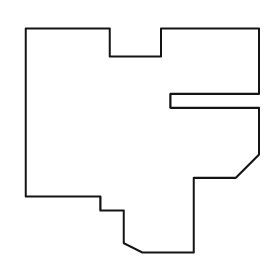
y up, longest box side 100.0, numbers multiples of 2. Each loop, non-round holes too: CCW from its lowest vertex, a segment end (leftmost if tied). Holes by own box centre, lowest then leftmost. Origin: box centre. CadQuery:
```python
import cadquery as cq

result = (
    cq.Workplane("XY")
    .moveTo(0.0, -48.0)
    .lineTo(22.0, -48.0)
    .lineTo(22.0, -16.0)
    .lineTo(40.0, -16.0)
    .lineTo(50.0, -6.0)
    .lineTo(50.0, 14.0)
    .lineTo(12.0, 14.0)
    .lineTo(12.0, 20.0)
    .lineTo(50.0, 20.0)
    .lineTo(50.0, 48.0)
    .lineTo(8.0, 48.0)
    .lineTo(8.0, 36.0)
    .lineTo(-14.0, 36.0)
    .lineTo(-14.0, 48.0)
    .lineTo(-50.0, 48.0)
    .lineTo(-50.0, -24.0)
    .lineTo(-18.0, -24.0)
    .lineTo(-18.0, -30.0)
    .lineTo(-8.0, -30.0)
    .lineTo(-8.0, -44.0)
    .close()
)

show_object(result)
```